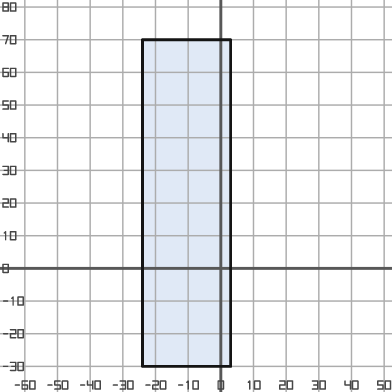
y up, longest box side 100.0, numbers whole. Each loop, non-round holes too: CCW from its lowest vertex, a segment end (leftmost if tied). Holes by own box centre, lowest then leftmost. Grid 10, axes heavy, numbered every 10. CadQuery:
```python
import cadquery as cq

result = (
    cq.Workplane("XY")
    .moveTo(-24.0, -30.0)
    .lineTo(3.0, -30.0)
    .lineTo(3.0, 70.0)
    .lineTo(-24.0, 70.0)
    .close()
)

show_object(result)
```